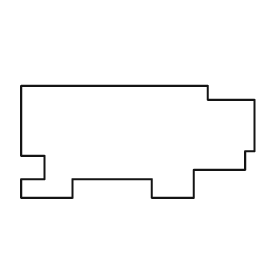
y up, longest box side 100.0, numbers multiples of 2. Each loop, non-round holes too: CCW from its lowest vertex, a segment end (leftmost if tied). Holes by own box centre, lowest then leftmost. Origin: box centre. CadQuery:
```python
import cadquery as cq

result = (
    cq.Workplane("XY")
    .moveTo(-50.0, -24.0)
    .lineTo(-28.0, -24.0)
    .lineTo(-28.0, -16.0)
    .lineTo(6.0, -16.0)
    .lineTo(6.0, -24.0)
    .lineTo(24.0, -24.0)
    .lineTo(24.0, -12.0)
    .lineTo(46.0, -12.0)
    .lineTo(46.0, -4.0)
    .lineTo(50.0, -4.0)
    .lineTo(50.0, 18.0)
    .lineTo(30.0, 18.0)
    .lineTo(30.0, 24.0)
    .lineTo(-50.0, 24.0)
    .lineTo(-50.0, -6.0)
    .lineTo(-40.0, -6.0)
    .lineTo(-40.0, -16.0)
    .lineTo(-50.0, -16.0)
    .close()
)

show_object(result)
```